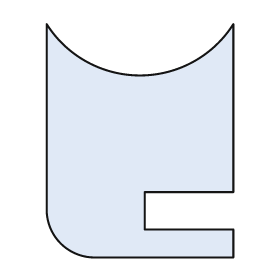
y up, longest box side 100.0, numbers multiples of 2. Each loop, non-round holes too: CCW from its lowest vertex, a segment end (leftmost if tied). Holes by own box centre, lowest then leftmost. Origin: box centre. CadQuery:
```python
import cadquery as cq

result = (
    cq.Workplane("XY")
    .moveTo(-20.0, -50.0)
    .lineTo(40.0, -50.0)
    .lineTo(40.0, -38.0)
    .lineTo(2.0, -38.0)
    .lineTo(2.0, -22.0)
    .lineTo(40.0, -22.0)
    .lineTo(40.0, 50.0)
    .threePointArc((0.0, 28.0), (-40.0, 50.0))
    .lineTo(-40.0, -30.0)
    .threePointArc((-34.0, -44.0), (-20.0, -50.0))
    .close()
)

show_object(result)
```